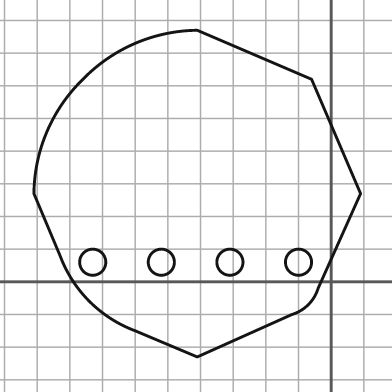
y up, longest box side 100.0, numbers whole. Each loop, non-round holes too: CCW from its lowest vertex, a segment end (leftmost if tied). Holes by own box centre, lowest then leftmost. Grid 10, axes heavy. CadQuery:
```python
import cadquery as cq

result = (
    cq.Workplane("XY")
    .moveTo(-41.0, -23.0)
    .lineTo(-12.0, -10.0)
    .threePointArc((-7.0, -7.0), (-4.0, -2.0))
    .lineTo(9.0, 27.0)
    .lineTo(-6.0, 62.0)
    .lineTo(-41.0, 77.0)
    .threePointArc((-60.0, 73.0), (-76.0, 62.0))
    .threePointArc((-87.0, 46.0), (-91.0, 27.0))
    .lineTo(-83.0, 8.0)
    .threePointArc((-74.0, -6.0), (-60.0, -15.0))
    .close()
    .moveTo(-73.0, 6.0)
    .circle(4.0)
    .moveTo(-52.0, 6.0)
    .circle(4.0)
    .moveTo(-31.0, 6.0)
    .circle(4.0)
    .moveTo(-10.0, 6.0)
    .circle(4.0)
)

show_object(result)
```